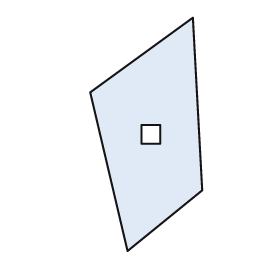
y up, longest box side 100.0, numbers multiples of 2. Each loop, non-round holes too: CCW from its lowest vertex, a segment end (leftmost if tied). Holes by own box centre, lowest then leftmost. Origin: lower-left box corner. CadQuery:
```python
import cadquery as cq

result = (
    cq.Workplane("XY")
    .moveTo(16.0, 0.0)
    .lineTo(48.0, 26.0)
    .lineTo(44.0, 100.0)
    .lineTo(0.0, 68.0)
    .close()
    .moveTo(22.0, 46.0)
    .lineTo(30.0, 46.0)
    .lineTo(30.0, 54.0)
    .lineTo(22.0, 54.0)
    .close()
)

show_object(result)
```